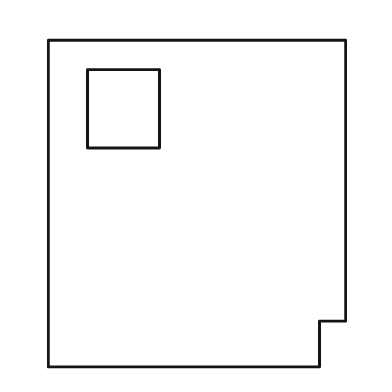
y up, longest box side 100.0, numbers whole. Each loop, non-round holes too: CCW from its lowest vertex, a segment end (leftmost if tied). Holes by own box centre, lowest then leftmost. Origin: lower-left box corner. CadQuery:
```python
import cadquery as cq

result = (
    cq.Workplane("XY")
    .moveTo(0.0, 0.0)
    .lineTo(83.0, 0.0)
    .lineTo(83.0, 14.0)
    .lineTo(91.0, 14.0)
    .lineTo(91.0, 100.0)
    .lineTo(0.0, 100.0)
    .close()
    .moveTo(12.0, 67.0)
    .lineTo(34.0, 67.0)
    .lineTo(34.0, 91.0)
    .lineTo(12.0, 91.0)
    .close()
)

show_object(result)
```